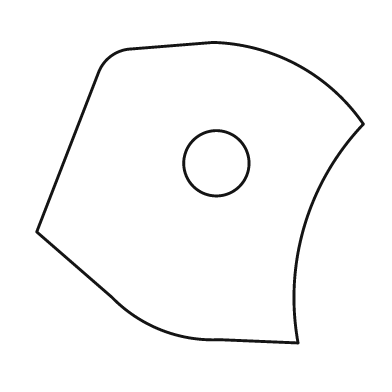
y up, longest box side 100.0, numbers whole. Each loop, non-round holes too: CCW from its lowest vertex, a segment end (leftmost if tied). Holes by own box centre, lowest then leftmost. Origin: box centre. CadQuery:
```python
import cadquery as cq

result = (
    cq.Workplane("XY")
    .moveTo(30.0, -46.0)
    .threePointArc((32.0, -10.0), (50.0, 21.0))
    .threePointArc((30.0, 39.0), (4.0, 46.0))
    .lineTo(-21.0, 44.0)
    .threePointArc((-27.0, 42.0), (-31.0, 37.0))
    .lineTo(-50.0, -12.0)
    .lineTo(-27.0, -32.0)
    .threePointArc((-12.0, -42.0), (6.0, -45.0))
    .close()
    .moveTo(5.0, 9.0)
    .circle(10.0)
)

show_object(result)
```